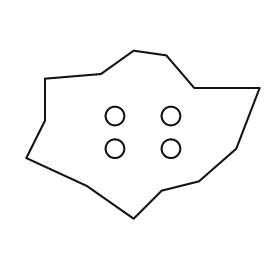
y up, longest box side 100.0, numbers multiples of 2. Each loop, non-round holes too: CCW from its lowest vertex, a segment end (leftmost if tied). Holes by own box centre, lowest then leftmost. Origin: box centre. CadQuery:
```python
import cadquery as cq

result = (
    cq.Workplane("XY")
    .moveTo(-4.0, -36.0)
    .lineTo(8.0, -24.0)
    .lineTo(24.0, -20.0)
    .lineTo(40.0, -6.0)
    .lineTo(50.0, 20.0)
    .lineTo(22.0, 20.0)
    .lineTo(10.0, 34.0)
    .lineTo(-4.0, 36.0)
    .lineTo(-18.0, 26.0)
    .lineTo(-42.0, 24.0)
    .lineTo(-42.0, 6.0)
    .lineTo(-50.0, -10.0)
    .lineTo(-24.0, -22.0)
    .close()
    .moveTo(-12.0, -6.0)
    .circle(4.0)
    .moveTo(12.0, -6.0)
    .circle(4.0)
    .moveTo(-12.0, 8.0)
    .circle(4.0)
    .moveTo(12.0, 8.0)
    .circle(4.0)
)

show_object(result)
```